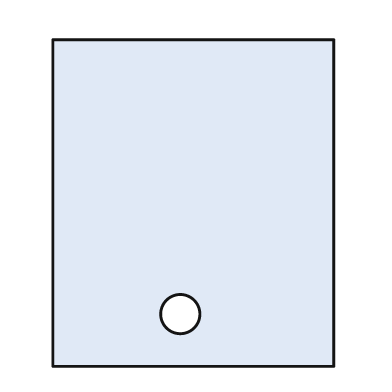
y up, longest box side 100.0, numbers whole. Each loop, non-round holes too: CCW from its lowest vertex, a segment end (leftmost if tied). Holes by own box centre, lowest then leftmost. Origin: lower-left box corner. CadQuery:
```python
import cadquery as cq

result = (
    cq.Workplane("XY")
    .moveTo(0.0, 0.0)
    .lineTo(86.0, 0.0)
    .lineTo(86.0, 100.0)
    .lineTo(0.0, 100.0)
    .close()
    .moveTo(39.0, 16.0)
    .circle(6.0)
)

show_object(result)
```